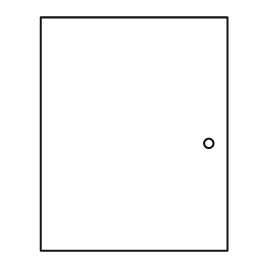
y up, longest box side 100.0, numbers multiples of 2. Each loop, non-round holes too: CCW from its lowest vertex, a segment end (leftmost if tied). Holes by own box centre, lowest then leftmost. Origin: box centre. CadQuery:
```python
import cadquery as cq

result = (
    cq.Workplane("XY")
    .moveTo(-40.0, -50.0)
    .lineTo(40.0, -50.0)
    .lineTo(40.0, 50.0)
    .lineTo(-40.0, 50.0)
    .close()
    .moveTo(32.0, -4.0)
    .circle(2.0)
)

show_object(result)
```